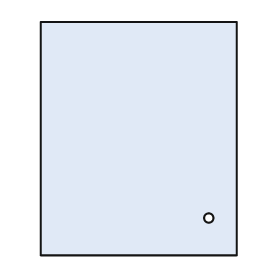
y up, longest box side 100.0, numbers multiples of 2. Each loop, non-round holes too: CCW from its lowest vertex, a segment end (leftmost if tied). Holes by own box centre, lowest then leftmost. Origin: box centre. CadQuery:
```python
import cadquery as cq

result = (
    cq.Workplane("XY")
    .moveTo(-42.0, -50.0)
    .lineTo(42.0, -50.0)
    .lineTo(42.0, 50.0)
    .lineTo(-42.0, 50.0)
    .close()
    .moveTo(30.0, -34.0)
    .circle(2.0)
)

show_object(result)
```